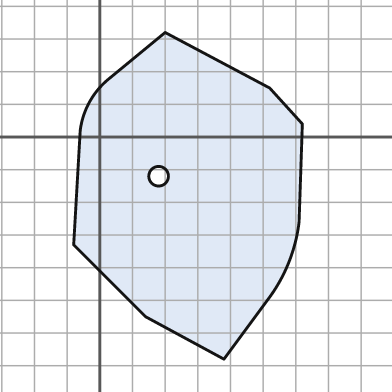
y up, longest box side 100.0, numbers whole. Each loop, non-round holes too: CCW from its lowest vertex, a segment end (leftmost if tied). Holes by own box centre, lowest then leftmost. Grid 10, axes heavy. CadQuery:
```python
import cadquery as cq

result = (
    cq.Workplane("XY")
    .moveTo(38.0, -68.0)
    .lineTo(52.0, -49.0)
    .threePointArc((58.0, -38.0), (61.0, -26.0))
    .lineTo(62.0, 4.0)
    .lineTo(52.0, 15.0)
    .lineTo(20.0, 32.0)
    .lineTo(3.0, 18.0)
    .threePointArc((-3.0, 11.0), (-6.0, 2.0))
    .lineTo(-8.0, -33.0)
    .lineTo(14.0, -55.0)
    .close()
    .moveTo(18.0, -12.0)
    .circle(3.0)
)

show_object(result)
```